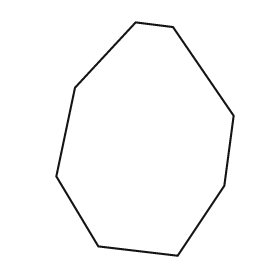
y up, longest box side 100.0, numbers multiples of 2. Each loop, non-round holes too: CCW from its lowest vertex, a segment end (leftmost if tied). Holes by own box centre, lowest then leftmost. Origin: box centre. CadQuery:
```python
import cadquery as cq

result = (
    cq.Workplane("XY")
    .moveTo(14.0, -50.0)
    .lineTo(34.0, -20.0)
    .lineTo(38.0, 10.0)
    .lineTo(12.0, 48.0)
    .lineTo(-4.0, 50.0)
    .lineTo(-30.0, 22.0)
    .lineTo(-38.0, -16.0)
    .lineTo(-20.0, -46.0)
    .close()
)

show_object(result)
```